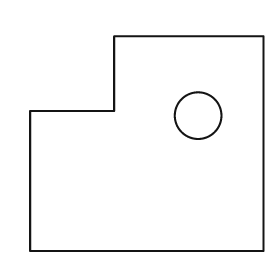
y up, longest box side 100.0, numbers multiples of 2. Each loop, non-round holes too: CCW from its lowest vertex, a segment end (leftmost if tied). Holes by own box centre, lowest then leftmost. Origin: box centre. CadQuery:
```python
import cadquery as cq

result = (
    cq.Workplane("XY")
    .moveTo(-50.0, -46.0)
    .lineTo(50.0, -46.0)
    .lineTo(50.0, 46.0)
    .lineTo(-14.0, 46.0)
    .lineTo(-14.0, 14.0)
    .lineTo(-50.0, 14.0)
    .close()
    .moveTo(22.0, 12.0)
    .circle(10.0)
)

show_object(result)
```